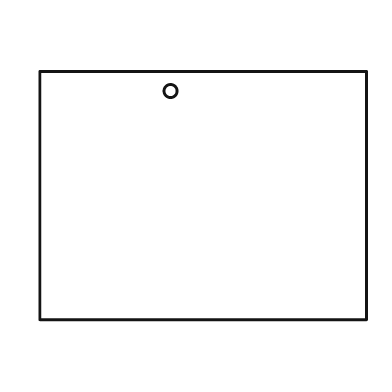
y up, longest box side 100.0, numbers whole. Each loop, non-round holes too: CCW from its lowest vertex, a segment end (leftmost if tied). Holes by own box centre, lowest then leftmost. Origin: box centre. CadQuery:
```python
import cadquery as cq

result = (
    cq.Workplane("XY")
    .moveTo(-50.0, -38.0)
    .lineTo(50.0, -38.0)
    .lineTo(50.0, 38.0)
    .lineTo(-50.0, 38.0)
    .close()
    .moveTo(-10.0, 32.0)
    .circle(2.0)
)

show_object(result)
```